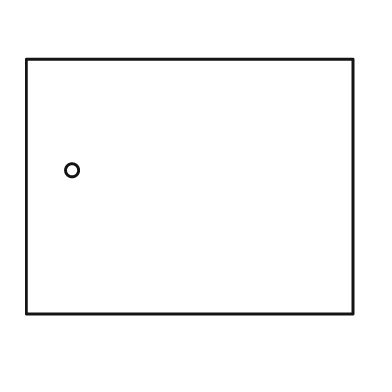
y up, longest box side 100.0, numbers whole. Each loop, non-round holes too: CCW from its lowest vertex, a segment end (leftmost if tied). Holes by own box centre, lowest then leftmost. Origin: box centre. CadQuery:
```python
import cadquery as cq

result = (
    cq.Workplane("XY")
    .moveTo(-50.0, -39.0)
    .lineTo(50.0, -39.0)
    .lineTo(50.0, 39.0)
    .lineTo(-50.0, 39.0)
    .close()
    .moveTo(-36.0, 5.0)
    .circle(2.0)
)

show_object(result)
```